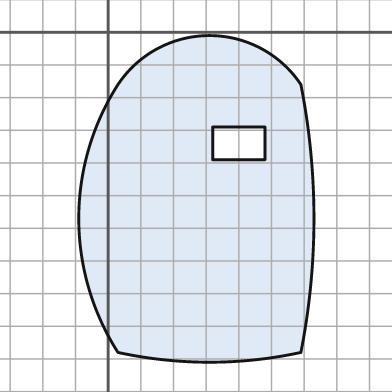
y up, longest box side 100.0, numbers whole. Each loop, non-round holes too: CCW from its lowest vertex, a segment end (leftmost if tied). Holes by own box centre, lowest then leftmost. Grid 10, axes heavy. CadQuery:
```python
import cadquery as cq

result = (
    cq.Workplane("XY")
    .moveTo(3.0, -98.0)
    .threePointArc((31.0, -101.0), (59.0, -98.0))
    .threePointArc((63.0, -57.0), (59.0, -16.0))
    .threePointArc((31.0, -1.0), (3.0, -16.0))
    .threePointArc((-9.0, -57.0), (3.0, -98.0))
    .close()
    .moveTo(32.0, -39.0)
    .lineTo(48.0, -39.0)
    .lineTo(48.0, -29.0)
    .lineTo(32.0, -29.0)
    .close()
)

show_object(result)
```